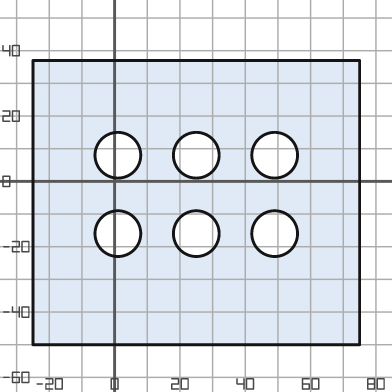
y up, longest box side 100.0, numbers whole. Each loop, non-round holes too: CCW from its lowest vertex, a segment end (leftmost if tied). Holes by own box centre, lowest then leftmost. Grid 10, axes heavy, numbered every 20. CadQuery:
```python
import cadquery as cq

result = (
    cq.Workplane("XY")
    .moveTo(-25.0, -50.0)
    .lineTo(75.0, -50.0)
    .lineTo(75.0, 37.0)
    .lineTo(-25.0, 37.0)
    .close()
    .moveTo(1.0, -16.0)
    .circle(7.0)
    .moveTo(25.0, -16.0)
    .circle(7.0)
    .moveTo(49.0, -16.0)
    .circle(7.0)
    .moveTo(1.0, 8.0)
    .circle(7.0)
    .moveTo(25.0, 8.0)
    .circle(7.0)
    .moveTo(49.0, 8.0)
    .circle(7.0)
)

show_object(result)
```